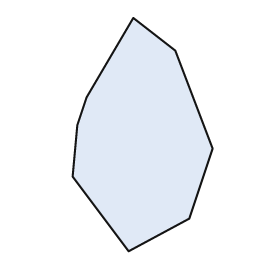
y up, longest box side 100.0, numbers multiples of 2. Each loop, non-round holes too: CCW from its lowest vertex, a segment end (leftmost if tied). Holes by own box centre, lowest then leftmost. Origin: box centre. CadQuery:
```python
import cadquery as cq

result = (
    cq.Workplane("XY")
    .moveTo(-6.0, -50.0)
    .lineTo(20.0, -36.0)
    .lineTo(30.0, -6.0)
    .lineTo(14.0, 36.0)
    .lineTo(-4.0, 50.0)
    .lineTo(-24.0, 16.0)
    .lineTo(-28.0, 4.0)
    .lineTo(-30.0, -18.0)
    .close()
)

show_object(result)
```